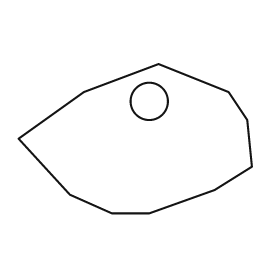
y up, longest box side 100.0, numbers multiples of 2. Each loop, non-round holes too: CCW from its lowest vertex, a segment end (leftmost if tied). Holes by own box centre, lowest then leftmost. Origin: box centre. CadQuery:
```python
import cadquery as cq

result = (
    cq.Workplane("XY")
    .moveTo(-10.0, -32.0)
    .lineTo(6.0, -32.0)
    .lineTo(34.0, -22.0)
    .lineTo(50.0, -12.0)
    .lineTo(48.0, 8.0)
    .lineTo(40.0, 20.0)
    .lineTo(10.0, 32.0)
    .lineTo(-22.0, 20.0)
    .lineTo(-50.0, 0.0)
    .lineTo(-28.0, -24.0)
    .close()
    .moveTo(6.0, 16.0)
    .circle(8.0)
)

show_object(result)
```